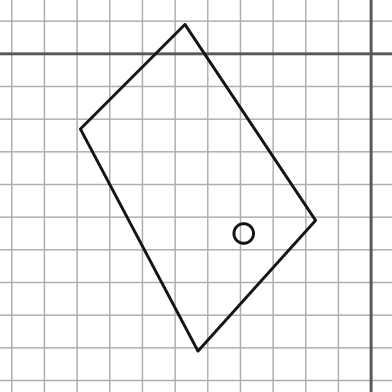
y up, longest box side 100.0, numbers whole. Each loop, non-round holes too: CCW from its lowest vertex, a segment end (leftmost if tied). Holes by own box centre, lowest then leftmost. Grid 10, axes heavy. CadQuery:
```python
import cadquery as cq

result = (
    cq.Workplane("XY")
    .moveTo(-53.0, -91.0)
    .lineTo(-17.0, -51.0)
    .lineTo(-57.0, 9.0)
    .lineTo(-89.0, -23.0)
    .close()
    .moveTo(-39.0, -55.0)
    .circle(3.0)
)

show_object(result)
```